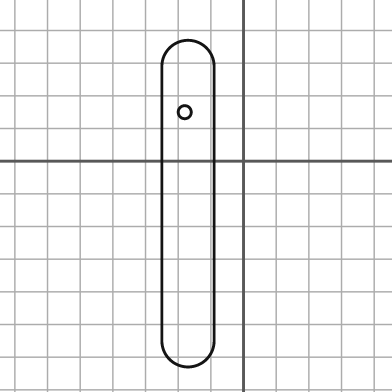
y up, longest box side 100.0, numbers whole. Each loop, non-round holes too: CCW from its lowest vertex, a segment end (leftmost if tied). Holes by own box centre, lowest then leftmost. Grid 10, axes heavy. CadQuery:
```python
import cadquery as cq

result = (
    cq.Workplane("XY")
    .moveTo(-25.0, -55.0)
    .threePointArc((-17.0, -63.0), (-9.0, -55.0))
    .lineTo(-9.0, 29.0)
    .threePointArc((-17.0, 37.0), (-25.0, 29.0))
    .close()
    .moveTo(-18.0, 15.0)
    .circle(2.0)
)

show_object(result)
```